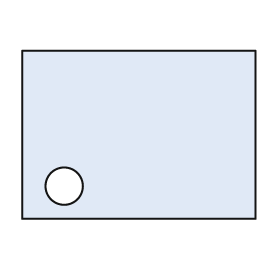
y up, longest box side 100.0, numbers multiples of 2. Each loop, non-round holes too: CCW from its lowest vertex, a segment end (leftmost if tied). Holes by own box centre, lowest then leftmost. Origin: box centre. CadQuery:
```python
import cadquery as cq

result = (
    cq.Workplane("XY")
    .moveTo(-50.0, -36.0)
    .lineTo(50.0, -36.0)
    .lineTo(50.0, 36.0)
    .lineTo(-50.0, 36.0)
    .close()
    .moveTo(-32.0, -22.0)
    .circle(8.0)
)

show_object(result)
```